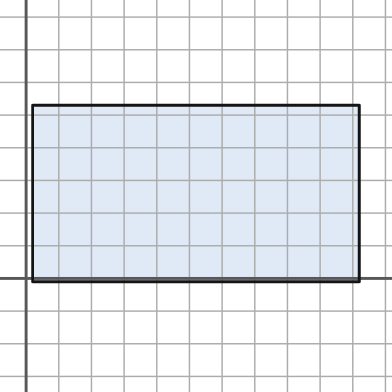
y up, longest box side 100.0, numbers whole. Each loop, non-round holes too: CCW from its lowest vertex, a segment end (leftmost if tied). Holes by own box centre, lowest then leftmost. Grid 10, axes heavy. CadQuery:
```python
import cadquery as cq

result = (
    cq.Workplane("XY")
    .moveTo(2.0, -1.0)
    .lineTo(102.0, -1.0)
    .lineTo(102.0, 53.0)
    .lineTo(2.0, 53.0)
    .close()
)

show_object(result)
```